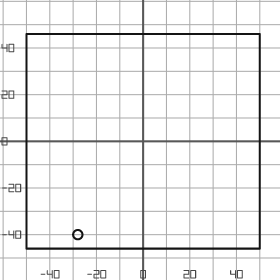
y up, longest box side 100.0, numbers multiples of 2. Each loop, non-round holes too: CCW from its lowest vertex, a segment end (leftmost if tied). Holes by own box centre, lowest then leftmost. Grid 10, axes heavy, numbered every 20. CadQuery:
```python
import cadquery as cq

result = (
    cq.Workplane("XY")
    .moveTo(-50.0, -46.0)
    .lineTo(50.0, -46.0)
    .lineTo(50.0, 46.0)
    .lineTo(-50.0, 46.0)
    .close()
    .moveTo(-28.0, -40.0)
    .circle(2.0)
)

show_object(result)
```